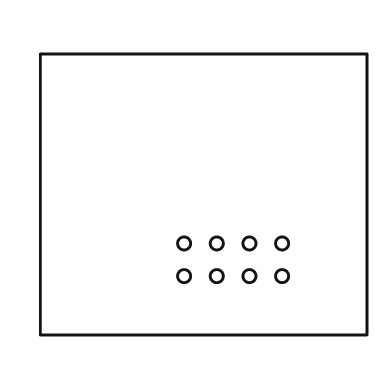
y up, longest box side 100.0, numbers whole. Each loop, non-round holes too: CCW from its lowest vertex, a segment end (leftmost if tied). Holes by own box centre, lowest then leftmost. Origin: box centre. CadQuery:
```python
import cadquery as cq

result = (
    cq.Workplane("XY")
    .moveTo(-50.0, -43.0)
    .lineTo(50.0, -43.0)
    .lineTo(50.0, 43.0)
    .lineTo(-50.0, 43.0)
    .close()
    .moveTo(-6.0, -25.0)
    .circle(2.0)
    .moveTo(4.0, -25.0)
    .circle(2.0)
    .moveTo(14.0, -25.0)
    .circle(2.0)
    .moveTo(24.0, -25.0)
    .circle(2.0)
    .moveTo(-6.0, -15.0)
    .circle(2.0)
    .moveTo(4.0, -15.0)
    .circle(2.0)
    .moveTo(14.0, -15.0)
    .circle(2.0)
    .moveTo(24.0, -15.0)
    .circle(2.0)
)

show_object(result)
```